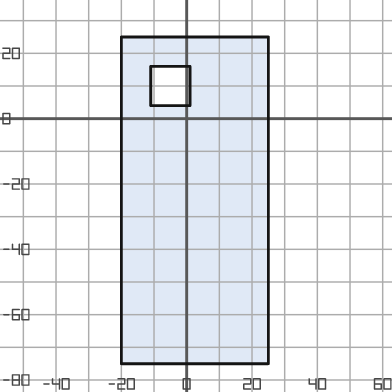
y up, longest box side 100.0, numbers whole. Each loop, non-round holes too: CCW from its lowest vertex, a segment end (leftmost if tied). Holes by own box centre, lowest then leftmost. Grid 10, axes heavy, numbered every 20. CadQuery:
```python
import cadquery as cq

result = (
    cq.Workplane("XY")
    .moveTo(-20.0, -75.0)
    .lineTo(25.0, -75.0)
    .lineTo(25.0, 25.0)
    .lineTo(-20.0, 25.0)
    .close()
    .moveTo(-11.0, 4.0)
    .lineTo(1.0, 4.0)
    .lineTo(1.0, 16.0)
    .lineTo(-11.0, 16.0)
    .close()
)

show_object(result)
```